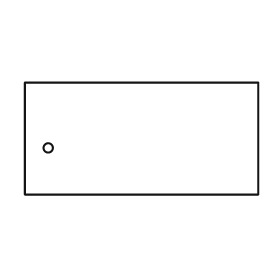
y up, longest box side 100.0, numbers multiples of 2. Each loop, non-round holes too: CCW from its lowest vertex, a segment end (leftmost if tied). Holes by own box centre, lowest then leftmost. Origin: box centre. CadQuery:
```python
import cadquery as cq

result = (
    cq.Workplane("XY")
    .moveTo(-50.0, -24.0)
    .lineTo(50.0, -24.0)
    .lineTo(50.0, 24.0)
    .lineTo(-50.0, 24.0)
    .close()
    .moveTo(-40.0, -4.0)
    .circle(2.0)
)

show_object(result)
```